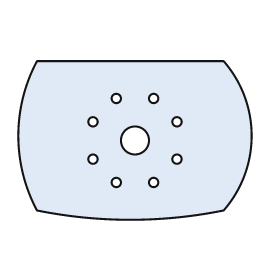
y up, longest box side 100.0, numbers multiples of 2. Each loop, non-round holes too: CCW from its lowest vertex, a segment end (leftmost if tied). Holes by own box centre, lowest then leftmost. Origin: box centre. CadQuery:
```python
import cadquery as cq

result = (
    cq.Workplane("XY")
    .moveTo(-42.0, -30.0)
    .threePointArc((-2.0, -34.0), (38.0, -30.0))
    .threePointArc((50.0, 2.0), (38.0, 34.0))
    .lineTo(-42.0, 34.0)
    .threePointArc((-50.0, 2.0), (-42.0, -30.0))
    .close()
    .moveTo(-8.0, -18.0)
    .circle(2.0)
    .moveTo(8.0, -18.0)
    .circle(2.0)
    .moveTo(-18.0, -8.0)
    .circle(2.0)
    .moveTo(18.0, -8.0)
    .circle(2.0)
    .moveTo(0.0, 0.0)
    .circle(6.0)
    .moveTo(-18.0, 8.0)
    .circle(2.0)
    .moveTo(18.0, 8.0)
    .circle(2.0)
    .moveTo(-8.0, 18.0)
    .circle(2.0)
    .moveTo(8.0, 18.0)
    .circle(2.0)
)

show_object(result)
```